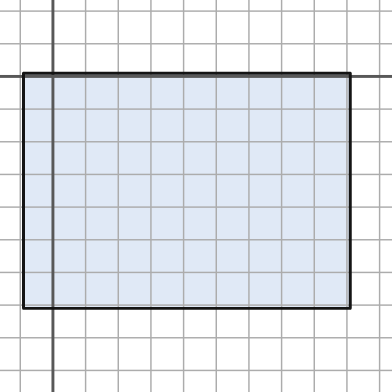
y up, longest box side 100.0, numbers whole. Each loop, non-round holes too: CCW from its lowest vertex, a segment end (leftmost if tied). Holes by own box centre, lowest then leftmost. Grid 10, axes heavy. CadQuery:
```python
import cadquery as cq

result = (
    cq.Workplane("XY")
    .moveTo(-9.0, -71.0)
    .lineTo(91.0, -71.0)
    .lineTo(91.0, 1.0)
    .lineTo(-9.0, 1.0)
    .close()
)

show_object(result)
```